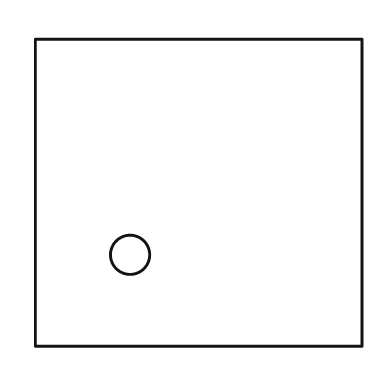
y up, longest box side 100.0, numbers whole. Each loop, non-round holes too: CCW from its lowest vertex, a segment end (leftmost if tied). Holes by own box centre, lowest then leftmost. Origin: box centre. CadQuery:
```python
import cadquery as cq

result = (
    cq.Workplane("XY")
    .moveTo(-50.0, -47.0)
    .lineTo(50.0, -47.0)
    .lineTo(50.0, 47.0)
    .lineTo(-50.0, 47.0)
    .close()
    .moveTo(-21.0, -19.0)
    .circle(6.0)
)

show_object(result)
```